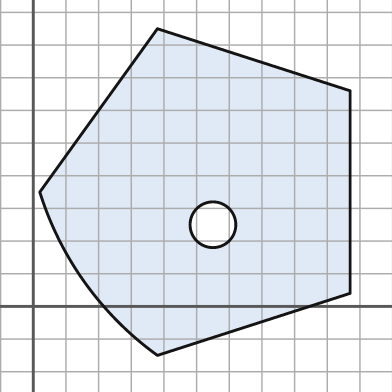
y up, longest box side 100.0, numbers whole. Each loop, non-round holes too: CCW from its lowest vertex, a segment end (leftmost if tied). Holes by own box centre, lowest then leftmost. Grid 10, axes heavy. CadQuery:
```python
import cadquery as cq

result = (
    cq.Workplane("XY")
    .moveTo(38.0, -15.0)
    .lineTo(97.0, 4.0)
    .lineTo(97.0, 66.0)
    .lineTo(38.0, 85.0)
    .lineTo(2.0, 35.0)
    .threePointArc((16.0, 7.0), (38.0, -15.0))
    .close()
    .moveTo(55.0, 25.0)
    .circle(7.0)
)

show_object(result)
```